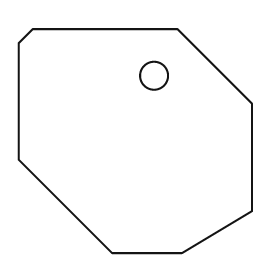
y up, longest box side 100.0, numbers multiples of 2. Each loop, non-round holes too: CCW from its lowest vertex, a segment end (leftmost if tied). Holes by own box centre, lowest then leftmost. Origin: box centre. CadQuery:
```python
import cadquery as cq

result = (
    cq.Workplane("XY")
    .moveTo(-10.0, -48.0)
    .lineTo(20.0, -48.0)
    .lineTo(50.0, -30.0)
    .lineTo(50.0, 16.0)
    .lineTo(18.0, 48.0)
    .lineTo(-44.0, 48.0)
    .lineTo(-50.0, 42.0)
    .lineTo(-50.0, -8.0)
    .close()
    .moveTo(8.0, 28.0)
    .circle(6.0)
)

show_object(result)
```